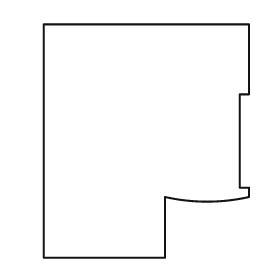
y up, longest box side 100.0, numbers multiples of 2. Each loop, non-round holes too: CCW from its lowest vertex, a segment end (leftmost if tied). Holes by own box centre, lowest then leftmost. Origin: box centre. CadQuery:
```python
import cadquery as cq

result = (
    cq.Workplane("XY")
    .moveTo(-44.0, -50.0)
    .lineTo(8.0, -50.0)
    .lineTo(8.0, -24.0)
    .threePointArc((26.0, -26.0), (44.0, -24.0))
    .lineTo(44.0, -20.0)
    .lineTo(40.0, -20.0)
    .lineTo(40.0, 20.0)
    .lineTo(44.0, 20.0)
    .lineTo(44.0, 50.0)
    .lineTo(-44.0, 50.0)
    .close()
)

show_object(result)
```